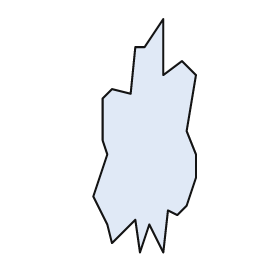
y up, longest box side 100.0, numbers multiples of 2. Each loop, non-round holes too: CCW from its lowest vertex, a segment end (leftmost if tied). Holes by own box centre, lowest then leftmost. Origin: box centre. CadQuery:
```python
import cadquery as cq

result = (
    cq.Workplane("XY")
    .moveTo(-2.0, -50.0)
    .lineTo(2.0, -38.0)
    .lineTo(8.0, -50.0)
    .lineTo(10.0, -32.0)
    .lineTo(14.0, -34.0)
    .lineTo(18.0, -30.0)
    .lineTo(22.0, -18.0)
    .lineTo(22.0, -8.0)
    .lineTo(18.0, 2.0)
    .lineTo(22.0, 26.0)
    .lineTo(16.0, 32.0)
    .lineTo(8.0, 26.0)
    .lineTo(8.0, 50.0)
    .lineTo(0.0, 38.0)
    .lineTo(-4.0, 38.0)
    .lineTo(-6.0, 18.0)
    .lineTo(-14.0, 20.0)
    .lineTo(-18.0, 16.0)
    .lineTo(-18.0, -2.0)
    .lineTo(-16.0, -8.0)
    .lineTo(-22.0, -26.0)
    .lineTo(-16.0, -38.0)
    .lineTo(-14.0, -46.0)
    .lineTo(-4.0, -36.0)
    .close()
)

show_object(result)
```